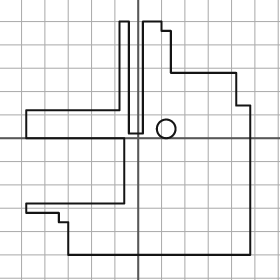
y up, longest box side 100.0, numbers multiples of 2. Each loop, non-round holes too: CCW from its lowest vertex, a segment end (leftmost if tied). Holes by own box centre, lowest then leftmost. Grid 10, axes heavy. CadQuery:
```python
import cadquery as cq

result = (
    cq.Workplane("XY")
    .moveTo(-30.0, -50.0)
    .lineTo(48.0, -50.0)
    .lineTo(48.0, 14.0)
    .lineTo(42.0, 14.0)
    .lineTo(42.0, 28.0)
    .lineTo(14.0, 28.0)
    .lineTo(14.0, 46.0)
    .lineTo(10.0, 46.0)
    .lineTo(10.0, 50.0)
    .lineTo(2.0, 50.0)
    .lineTo(2.0, 2.0)
    .lineTo(-4.0, 2.0)
    .lineTo(-4.0, 50.0)
    .lineTo(-8.0, 50.0)
    .lineTo(-8.0, 12.0)
    .lineTo(-48.0, 12.0)
    .lineTo(-48.0, 0.0)
    .lineTo(-6.0, 0.0)
    .lineTo(-6.0, -28.0)
    .lineTo(-48.0, -28.0)
    .lineTo(-48.0, -32.0)
    .lineTo(-34.0, -32.0)
    .lineTo(-34.0, -36.0)
    .lineTo(-30.0, -36.0)
    .close()
    .moveTo(12.0, 4.0)
    .circle(4.0)
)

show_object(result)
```